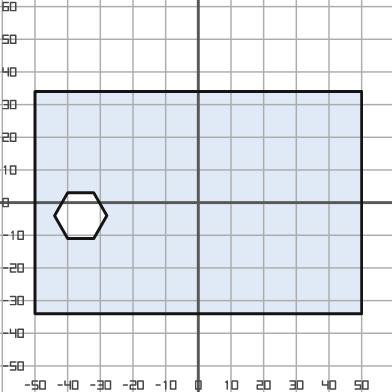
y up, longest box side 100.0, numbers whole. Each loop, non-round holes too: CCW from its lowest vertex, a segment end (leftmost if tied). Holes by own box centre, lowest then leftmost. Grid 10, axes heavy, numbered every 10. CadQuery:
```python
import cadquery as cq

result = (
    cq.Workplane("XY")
    .moveTo(-50.0, -34.0)
    .lineTo(50.0, -34.0)
    .lineTo(50.0, 34.0)
    .lineTo(-50.0, 34.0)
    .close()
    .moveTo(-40.0, -11.0)
    .lineTo(-32.0, -11.0)
    .lineTo(-28.0, -4.0)
    .lineTo(-32.0, 3.0)
    .lineTo(-40.0, 3.0)
    .lineTo(-44.0, -4.0)
    .close()
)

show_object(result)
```